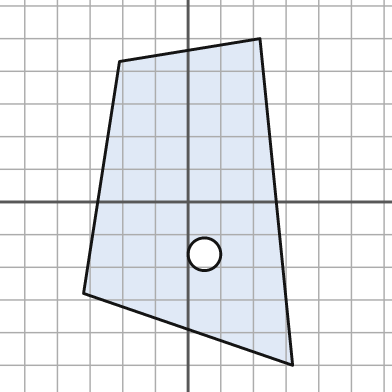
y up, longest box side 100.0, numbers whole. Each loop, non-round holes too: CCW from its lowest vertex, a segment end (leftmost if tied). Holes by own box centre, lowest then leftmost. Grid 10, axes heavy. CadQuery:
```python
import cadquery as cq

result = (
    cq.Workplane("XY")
    .moveTo(32.0, -50.0)
    .lineTo(22.0, 50.0)
    .lineTo(-21.0, 43.0)
    .lineTo(-32.0, -28.0)
    .close()
    .moveTo(5.0, -16.0)
    .circle(5.0)
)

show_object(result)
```